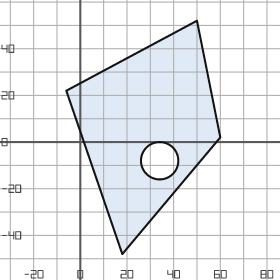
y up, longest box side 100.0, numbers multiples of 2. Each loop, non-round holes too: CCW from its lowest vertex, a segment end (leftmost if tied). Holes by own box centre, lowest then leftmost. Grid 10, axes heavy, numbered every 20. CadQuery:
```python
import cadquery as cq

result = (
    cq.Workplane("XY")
    .moveTo(18.0, -48.0)
    .lineTo(60.0, 2.0)
    .lineTo(50.0, 52.0)
    .lineTo(-6.0, 22.0)
    .close()
    .moveTo(34.0, -8.0)
    .circle(8.0)
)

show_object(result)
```